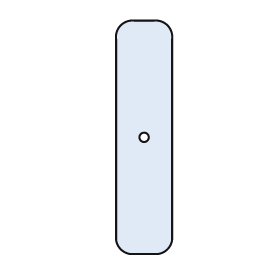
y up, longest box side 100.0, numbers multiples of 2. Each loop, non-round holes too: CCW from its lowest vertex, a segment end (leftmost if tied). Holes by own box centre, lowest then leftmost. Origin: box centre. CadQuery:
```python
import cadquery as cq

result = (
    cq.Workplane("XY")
    .moveTo(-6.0, -50.0)
    .lineTo(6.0, -50.0)
    .threePointArc((10.0, -48.0), (12.0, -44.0))
    .lineTo(12.0, 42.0)
    .threePointArc((10.0, 48.0), (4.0, 50.0))
    .lineTo(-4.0, 50.0)
    .threePointArc((-10.0, 48.0), (-12.0, 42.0))
    .lineTo(-12.0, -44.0)
    .threePointArc((-10.0, -48.0), (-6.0, -50.0))
    .close()
    .moveTo(0.0, 0.0)
    .circle(2.0)
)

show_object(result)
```